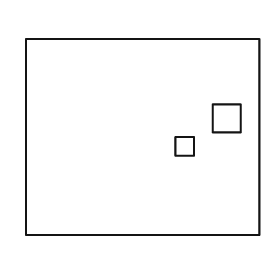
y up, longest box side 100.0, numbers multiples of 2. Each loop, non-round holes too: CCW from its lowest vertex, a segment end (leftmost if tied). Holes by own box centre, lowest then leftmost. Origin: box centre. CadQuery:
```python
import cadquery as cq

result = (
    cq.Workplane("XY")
    .moveTo(-50.0, -42.0)
    .lineTo(50.0, -42.0)
    .lineTo(50.0, 42.0)
    .lineTo(-50.0, 42.0)
    .close()
    .moveTo(14.0, -8.0)
    .lineTo(22.0, -8.0)
    .lineTo(22.0, 0.0)
    .lineTo(14.0, 0.0)
    .close()
    .moveTo(30.0, 2.0)
    .lineTo(42.0, 2.0)
    .lineTo(42.0, 14.0)
    .lineTo(30.0, 14.0)
    .close()
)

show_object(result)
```